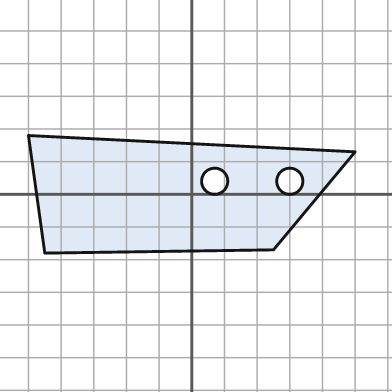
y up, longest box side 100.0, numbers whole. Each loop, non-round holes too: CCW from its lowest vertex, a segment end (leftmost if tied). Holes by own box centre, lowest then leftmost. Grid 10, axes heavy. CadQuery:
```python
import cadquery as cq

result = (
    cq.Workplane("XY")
    .moveTo(-45.0, -18.0)
    .lineTo(25.0, -17.0)
    .lineTo(50.0, 13.0)
    .lineTo(-50.0, 18.0)
    .close()
    .moveTo(7.0, 4.0)
    .circle(4.0)
    .moveTo(30.0, 4.0)
    .circle(4.0)
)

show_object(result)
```